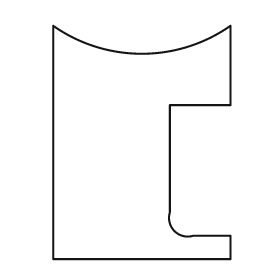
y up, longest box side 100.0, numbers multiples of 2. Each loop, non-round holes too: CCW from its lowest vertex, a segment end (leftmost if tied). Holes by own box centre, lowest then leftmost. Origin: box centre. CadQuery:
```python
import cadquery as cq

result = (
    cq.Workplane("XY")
    .moveTo(-38.0, -50.0)
    .lineTo(38.0, -50.0)
    .lineTo(38.0, -40.0)
    .lineTo(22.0, -40.0)
    .threePointArc((14.0, -38.0), (12.0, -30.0))
    .lineTo(12.0, 16.0)
    .lineTo(38.0, 16.0)
    .lineTo(38.0, 50.0)
    .threePointArc((0.0, 38.0), (-38.0, 50.0))
    .close()
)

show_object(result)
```